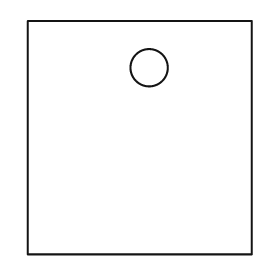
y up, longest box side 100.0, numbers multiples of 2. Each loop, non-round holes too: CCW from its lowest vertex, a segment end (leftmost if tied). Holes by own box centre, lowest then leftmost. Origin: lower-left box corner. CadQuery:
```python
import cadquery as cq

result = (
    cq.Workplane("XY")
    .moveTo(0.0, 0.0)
    .lineTo(96.0, 0.0)
    .lineTo(96.0, 100.0)
    .lineTo(0.0, 100.0)
    .close()
    .moveTo(52.0, 80.0)
    .circle(8.0)
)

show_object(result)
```